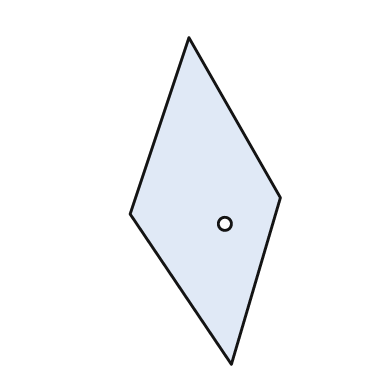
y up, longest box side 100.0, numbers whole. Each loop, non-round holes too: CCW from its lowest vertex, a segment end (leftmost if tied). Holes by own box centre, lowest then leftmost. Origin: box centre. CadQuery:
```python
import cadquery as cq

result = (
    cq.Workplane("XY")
    .moveTo(8.0, -50.0)
    .lineTo(23.0, 1.0)
    .lineTo(-5.0, 50.0)
    .lineTo(-23.0, -4.0)
    .close()
    .moveTo(6.0, -7.0)
    .circle(2.0)
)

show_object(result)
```